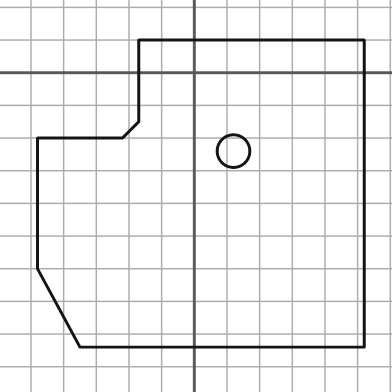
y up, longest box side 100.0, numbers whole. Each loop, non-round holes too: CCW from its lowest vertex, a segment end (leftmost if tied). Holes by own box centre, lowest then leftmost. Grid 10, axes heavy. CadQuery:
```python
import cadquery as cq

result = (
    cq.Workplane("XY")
    .moveTo(-35.0, -84.0)
    .lineTo(52.0, -84.0)
    .lineTo(52.0, 10.0)
    .lineTo(-17.0, 10.0)
    .lineTo(-17.0, -15.0)
    .lineTo(-22.0, -20.0)
    .lineTo(-48.0, -20.0)
    .lineTo(-48.0, -60.0)
    .close()
    .moveTo(12.0, -24.0)
    .circle(5.0)
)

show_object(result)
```